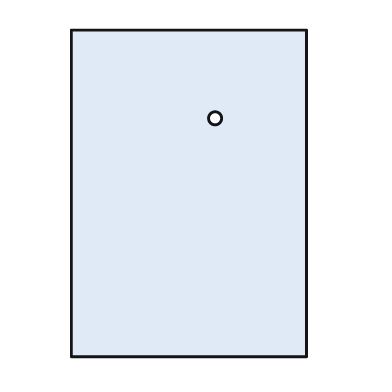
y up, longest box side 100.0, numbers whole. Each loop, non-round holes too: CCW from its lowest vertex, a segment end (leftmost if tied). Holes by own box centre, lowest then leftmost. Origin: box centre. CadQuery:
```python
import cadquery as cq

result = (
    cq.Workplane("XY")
    .moveTo(-36.0, -50.0)
    .lineTo(36.0, -50.0)
    .lineTo(36.0, 50.0)
    .lineTo(-36.0, 50.0)
    .close()
    .moveTo(8.0, 23.0)
    .circle(2.0)
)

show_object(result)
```